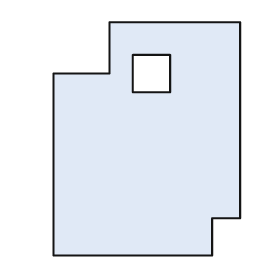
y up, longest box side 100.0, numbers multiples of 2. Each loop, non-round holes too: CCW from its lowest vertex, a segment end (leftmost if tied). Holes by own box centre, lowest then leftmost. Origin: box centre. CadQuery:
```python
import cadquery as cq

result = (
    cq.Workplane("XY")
    .moveTo(-40.0, -50.0)
    .lineTo(28.0, -50.0)
    .lineTo(28.0, -34.0)
    .lineTo(40.0, -34.0)
    .lineTo(40.0, 50.0)
    .lineTo(-16.0, 50.0)
    .lineTo(-16.0, 28.0)
    .lineTo(-40.0, 28.0)
    .close()
    .moveTo(-6.0, 20.0)
    .lineTo(10.0, 20.0)
    .lineTo(10.0, 36.0)
    .lineTo(-6.0, 36.0)
    .close()
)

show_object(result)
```